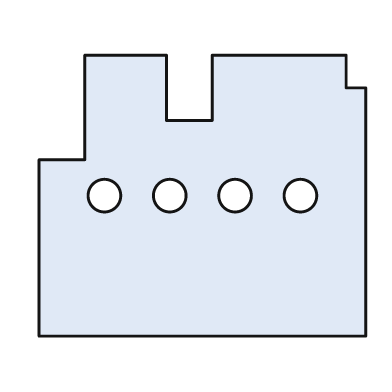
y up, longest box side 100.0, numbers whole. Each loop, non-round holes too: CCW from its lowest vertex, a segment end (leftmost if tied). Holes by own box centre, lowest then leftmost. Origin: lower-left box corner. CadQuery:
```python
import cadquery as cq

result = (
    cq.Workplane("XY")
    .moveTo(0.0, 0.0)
    .lineTo(100.0, 0.0)
    .lineTo(100.0, 76.0)
    .lineTo(94.0, 76.0)
    .lineTo(94.0, 86.0)
    .lineTo(53.0, 86.0)
    .lineTo(53.0, 66.0)
    .lineTo(39.0, 66.0)
    .lineTo(39.0, 86.0)
    .lineTo(14.0, 86.0)
    .lineTo(14.0, 54.0)
    .lineTo(0.0, 54.0)
    .close()
    .moveTo(20.0, 43.0)
    .circle(5.0)
    .moveTo(40.0, 43.0)
    .circle(5.0)
    .moveTo(60.0, 43.0)
    .circle(5.0)
    .moveTo(80.0, 43.0)
    .circle(5.0)
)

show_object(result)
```